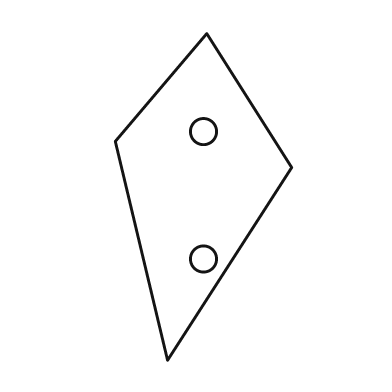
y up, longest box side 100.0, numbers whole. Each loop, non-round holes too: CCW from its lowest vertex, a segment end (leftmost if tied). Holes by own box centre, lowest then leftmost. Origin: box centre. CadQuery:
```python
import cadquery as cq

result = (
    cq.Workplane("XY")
    .moveTo(-11.0, -50.0)
    .lineTo(27.0, 9.0)
    .lineTo(1.0, 50.0)
    .lineTo(-27.0, 17.0)
    .close()
    .moveTo(0.0, -19.0)
    .circle(4.0)
    .moveTo(0.0, 20.0)
    .circle(4.0)
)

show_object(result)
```